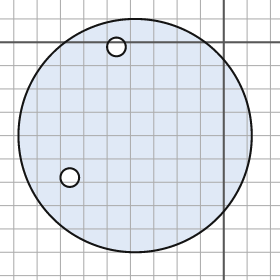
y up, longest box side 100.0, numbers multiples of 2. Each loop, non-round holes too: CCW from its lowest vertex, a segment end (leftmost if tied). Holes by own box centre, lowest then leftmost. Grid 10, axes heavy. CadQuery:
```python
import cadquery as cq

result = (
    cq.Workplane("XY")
    .moveTo(-38.0, -40.0)
    .circle(50.0)
    .moveTo(-66.0, -58.0)
    .circle(4.0)
    .moveTo(-46.0, -2.0)
    .circle(4.0)
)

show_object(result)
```